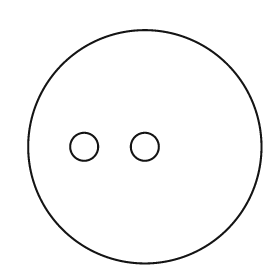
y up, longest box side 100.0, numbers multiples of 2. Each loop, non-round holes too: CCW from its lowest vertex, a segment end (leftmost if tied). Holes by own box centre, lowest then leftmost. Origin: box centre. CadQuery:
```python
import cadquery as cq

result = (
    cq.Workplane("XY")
    .moveTo(0.0, 0.0)
    .circle(50.0)
    .moveTo(-26.0, 0.0)
    .circle(6.0)
    .moveTo(0.0, 0.0)
    .circle(6.0)
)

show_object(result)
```